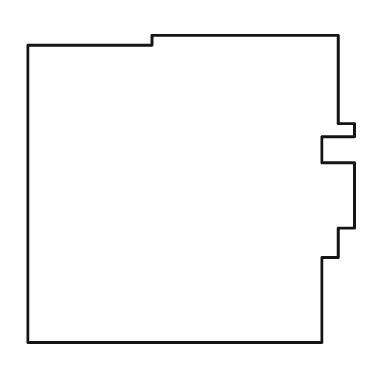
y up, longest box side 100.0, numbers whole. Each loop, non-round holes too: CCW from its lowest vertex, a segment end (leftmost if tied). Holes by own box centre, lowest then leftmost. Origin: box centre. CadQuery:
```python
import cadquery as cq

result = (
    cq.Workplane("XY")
    .moveTo(-50.0, -47.0)
    .lineTo(40.0, -47.0)
    .lineTo(40.0, -21.0)
    .lineTo(45.0, -21.0)
    .lineTo(45.0, -12.0)
    .lineTo(50.0, -12.0)
    .lineTo(50.0, 8.0)
    .lineTo(40.0, 8.0)
    .lineTo(40.0, 16.0)
    .lineTo(50.0, 16.0)
    .lineTo(50.0, 20.0)
    .lineTo(45.0, 20.0)
    .lineTo(45.0, 47.0)
    .lineTo(-12.0, 47.0)
    .lineTo(-12.0, 44.0)
    .lineTo(-50.0, 44.0)
    .close()
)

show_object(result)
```